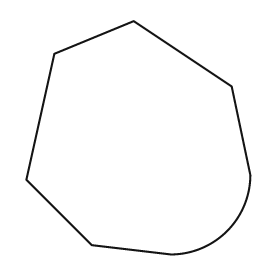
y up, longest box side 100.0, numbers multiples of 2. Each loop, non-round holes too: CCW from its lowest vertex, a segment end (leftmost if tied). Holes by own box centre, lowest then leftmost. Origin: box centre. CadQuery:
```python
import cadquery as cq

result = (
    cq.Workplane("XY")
    .moveTo(14.0, -50.0)
    .threePointArc((38.0, -40.0), (48.0, -16.0))
    .lineTo(40.0, 22.0)
    .lineTo(-2.0, 50.0)
    .lineTo(-36.0, 36.0)
    .lineTo(-48.0, -18.0)
    .lineTo(-20.0, -46.0)
    .close()
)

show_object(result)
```